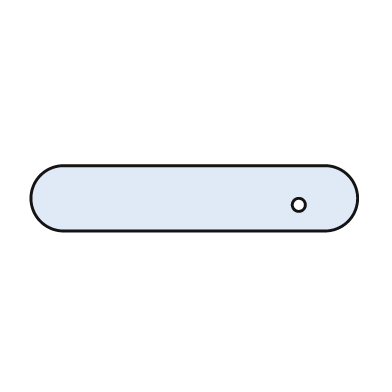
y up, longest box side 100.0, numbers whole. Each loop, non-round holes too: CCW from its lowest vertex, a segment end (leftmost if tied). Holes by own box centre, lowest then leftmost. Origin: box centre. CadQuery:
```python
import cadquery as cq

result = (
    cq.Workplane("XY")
    .moveTo(-40.0, -10.0)
    .lineTo(40.0, -10.0)
    .threePointArc((50.0, 0.0), (40.0, 10.0))
    .lineTo(-40.0, 10.0)
    .threePointArc((-50.0, 0.0), (-40.0, -10.0))
    .close()
    .moveTo(32.0, -2.0)
    .circle(2.0)
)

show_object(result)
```